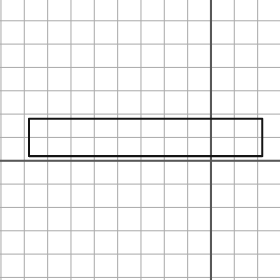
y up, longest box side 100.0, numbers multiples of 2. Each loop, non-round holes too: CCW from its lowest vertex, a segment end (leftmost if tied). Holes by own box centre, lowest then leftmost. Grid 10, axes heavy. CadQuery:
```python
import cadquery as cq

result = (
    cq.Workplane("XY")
    .moveTo(-78.0, 2.0)
    .lineTo(22.0, 2.0)
    .lineTo(22.0, 18.0)
    .lineTo(-78.0, 18.0)
    .close()
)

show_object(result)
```